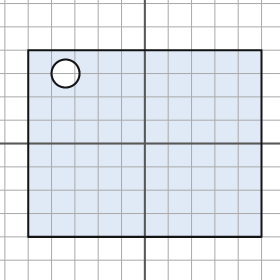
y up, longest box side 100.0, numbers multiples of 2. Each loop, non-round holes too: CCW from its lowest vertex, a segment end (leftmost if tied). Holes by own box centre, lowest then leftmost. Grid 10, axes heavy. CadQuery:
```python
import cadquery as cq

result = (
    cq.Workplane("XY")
    .moveTo(-50.0, -40.0)
    .lineTo(50.0, -40.0)
    .lineTo(50.0, 40.0)
    .lineTo(-50.0, 40.0)
    .close()
    .moveTo(-34.0, 30.0)
    .circle(6.0)
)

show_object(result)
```